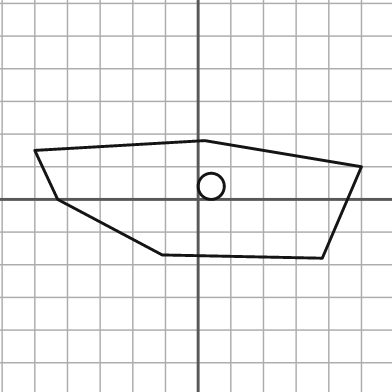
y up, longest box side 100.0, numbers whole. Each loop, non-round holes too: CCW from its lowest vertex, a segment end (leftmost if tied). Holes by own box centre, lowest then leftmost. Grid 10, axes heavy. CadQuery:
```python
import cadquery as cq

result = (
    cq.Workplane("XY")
    .moveTo(38.0, -18.0)
    .lineTo(50.0, 10.0)
    .lineTo(2.0, 18.0)
    .lineTo(-50.0, 15.0)
    .lineTo(-43.0, 0.0)
    .lineTo(-11.0, -17.0)
    .close()
    .moveTo(4.0, 4.0)
    .circle(4.0)
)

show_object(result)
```